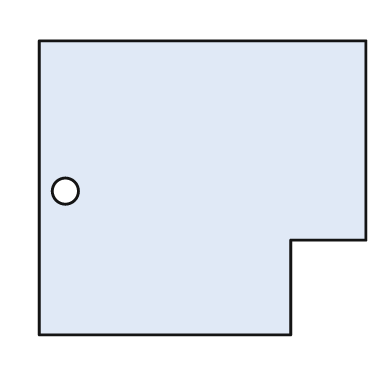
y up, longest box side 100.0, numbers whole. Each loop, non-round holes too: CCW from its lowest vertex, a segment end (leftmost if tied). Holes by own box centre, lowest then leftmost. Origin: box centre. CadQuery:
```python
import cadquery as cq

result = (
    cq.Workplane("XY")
    .moveTo(-50.0, -45.0)
    .lineTo(27.0, -45.0)
    .lineTo(27.0, -16.0)
    .lineTo(50.0, -16.0)
    .lineTo(50.0, 45.0)
    .lineTo(-50.0, 45.0)
    .close()
    .moveTo(-42.0, -1.0)
    .circle(4.0)
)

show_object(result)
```